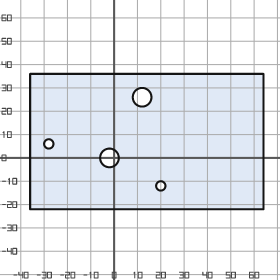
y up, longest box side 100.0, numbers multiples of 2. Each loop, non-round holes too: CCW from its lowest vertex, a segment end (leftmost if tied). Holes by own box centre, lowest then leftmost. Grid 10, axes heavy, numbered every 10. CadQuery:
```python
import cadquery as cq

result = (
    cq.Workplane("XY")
    .moveTo(-36.0, -22.0)
    .lineTo(64.0, -22.0)
    .lineTo(64.0, 36.0)
    .lineTo(-36.0, 36.0)
    .close()
    .moveTo(20.0, -12.0)
    .circle(2.0)
    .moveTo(-2.0, 0.0)
    .circle(4.0)
    .moveTo(-28.0, 6.0)
    .circle(2.0)
    .moveTo(12.0, 26.0)
    .circle(4.0)
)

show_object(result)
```